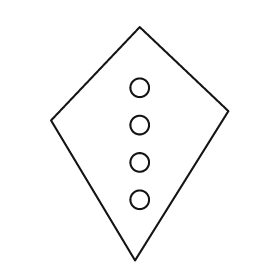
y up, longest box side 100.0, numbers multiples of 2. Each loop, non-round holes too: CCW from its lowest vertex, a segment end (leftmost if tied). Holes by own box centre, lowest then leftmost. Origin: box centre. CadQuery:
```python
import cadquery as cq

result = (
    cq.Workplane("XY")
    .moveTo(-2.0, -50.0)
    .lineTo(38.0, 14.0)
    .lineTo(0.0, 50.0)
    .lineTo(-38.0, 10.0)
    .close()
    .moveTo(0.0, -24.0)
    .circle(4.0)
    .moveTo(0.0, -8.0)
    .circle(4.0)
    .moveTo(0.0, 8.0)
    .circle(4.0)
    .moveTo(0.0, 24.0)
    .circle(4.0)
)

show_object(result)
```